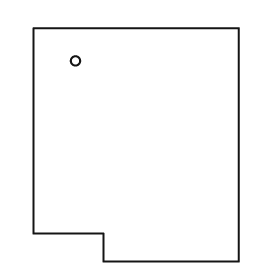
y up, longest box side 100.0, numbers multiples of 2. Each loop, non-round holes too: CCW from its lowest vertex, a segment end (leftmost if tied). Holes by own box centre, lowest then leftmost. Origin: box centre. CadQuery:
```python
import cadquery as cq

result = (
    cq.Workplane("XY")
    .moveTo(-14.0, -50.0)
    .lineTo(44.0, -50.0)
    .lineTo(44.0, 50.0)
    .lineTo(-44.0, 50.0)
    .lineTo(-44.0, -38.0)
    .lineTo(-14.0, -38.0)
    .close()
    .moveTo(-26.0, 36.0)
    .circle(2.0)
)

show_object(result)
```